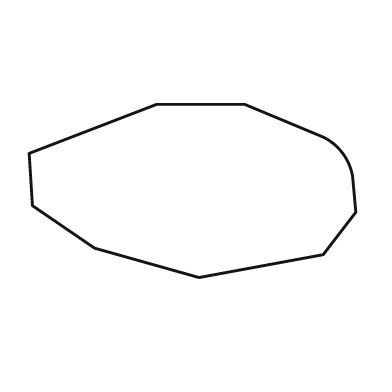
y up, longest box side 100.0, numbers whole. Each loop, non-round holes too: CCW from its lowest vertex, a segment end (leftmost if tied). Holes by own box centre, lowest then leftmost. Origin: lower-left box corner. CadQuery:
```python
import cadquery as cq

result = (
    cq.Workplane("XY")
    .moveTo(52.0, 0.0)
    .lineTo(90.0, 7.0)
    .lineTo(100.0, 20.0)
    .lineTo(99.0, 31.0)
    .threePointArc((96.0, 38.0), (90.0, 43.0))
    .lineTo(66.0, 53.0)
    .lineTo(39.0, 53.0)
    .lineTo(0.0, 38.0)
    .lineTo(1.0, 22.0)
    .lineTo(20.0, 9.0)
    .close()
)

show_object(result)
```